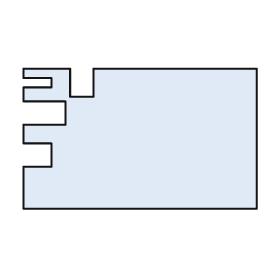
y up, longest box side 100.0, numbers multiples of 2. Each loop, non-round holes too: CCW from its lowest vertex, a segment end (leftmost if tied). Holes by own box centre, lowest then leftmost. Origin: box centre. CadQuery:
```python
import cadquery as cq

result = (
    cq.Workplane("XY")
    .moveTo(-50.0, -30.0)
    .lineTo(50.0, -30.0)
    .lineTo(50.0, 30.0)
    .lineTo(-20.0, 30.0)
    .lineTo(-20.0, 18.0)
    .lineTo(-30.0, 18.0)
    .lineTo(-30.0, 30.0)
    .lineTo(-50.0, 30.0)
    .lineTo(-50.0, 26.0)
    .lineTo(-38.0, 26.0)
    .lineTo(-38.0, 22.0)
    .lineTo(-50.0, 22.0)
    .lineTo(-50.0, 16.0)
    .lineTo(-32.0, 16.0)
    .lineTo(-32.0, 6.0)
    .lineTo(-50.0, 6.0)
    .lineTo(-50.0, -2.0)
    .lineTo(-38.0, -2.0)
    .lineTo(-38.0, -12.0)
    .lineTo(-50.0, -12.0)
    .close()
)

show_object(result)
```